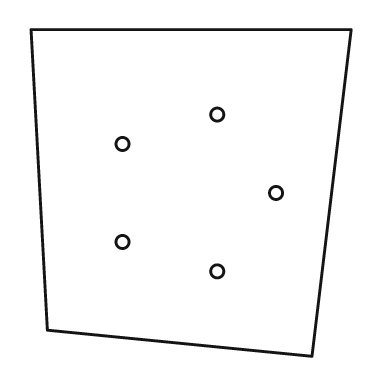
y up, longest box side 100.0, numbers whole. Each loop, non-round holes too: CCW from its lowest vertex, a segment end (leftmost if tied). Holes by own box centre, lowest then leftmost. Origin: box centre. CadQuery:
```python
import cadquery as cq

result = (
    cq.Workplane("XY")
    .moveTo(37.0, -50.0)
    .lineTo(49.0, 50.0)
    .lineTo(-49.0, 50.0)
    .lineTo(-44.0, -42.0)
    .close()
    .moveTo(8.0, -24.0)
    .circle(2.0)
    .moveTo(-21.0, -15.0)
    .circle(2.0)
    .moveTo(26.0, 0.0)
    .circle(2.0)
    .moveTo(-21.0, 15.0)
    .circle(2.0)
    .moveTo(8.0, 24.0)
    .circle(2.0)
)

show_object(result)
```